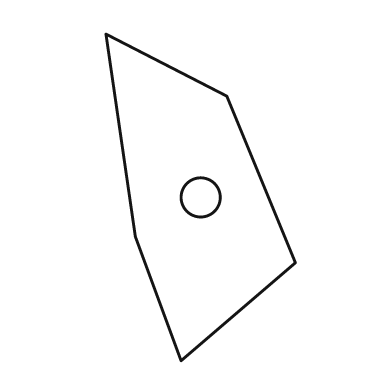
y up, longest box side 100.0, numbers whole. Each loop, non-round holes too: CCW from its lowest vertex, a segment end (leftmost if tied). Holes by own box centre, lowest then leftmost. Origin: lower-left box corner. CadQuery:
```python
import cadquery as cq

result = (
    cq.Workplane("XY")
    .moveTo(23.0, 0.0)
    .lineTo(58.0, 30.0)
    .lineTo(37.0, 81.0)
    .lineTo(0.0, 100.0)
    .lineTo(9.0, 38.0)
    .close()
    .moveTo(29.0, 50.0)
    .circle(6.0)
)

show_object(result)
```